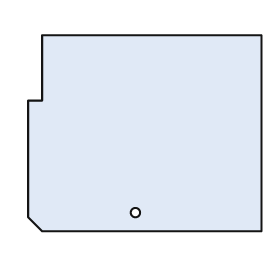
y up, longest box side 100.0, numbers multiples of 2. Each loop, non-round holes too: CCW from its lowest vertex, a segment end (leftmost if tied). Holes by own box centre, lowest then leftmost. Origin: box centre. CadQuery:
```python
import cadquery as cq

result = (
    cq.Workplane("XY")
    .moveTo(-44.0, -42.0)
    .lineTo(50.0, -42.0)
    .lineTo(50.0, 42.0)
    .lineTo(-44.0, 42.0)
    .lineTo(-44.0, 14.0)
    .lineTo(-50.0, 14.0)
    .lineTo(-50.0, -36.0)
    .close()
    .moveTo(-4.0, -34.0)
    .circle(2.0)
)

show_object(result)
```